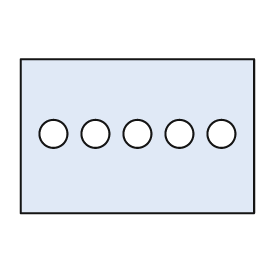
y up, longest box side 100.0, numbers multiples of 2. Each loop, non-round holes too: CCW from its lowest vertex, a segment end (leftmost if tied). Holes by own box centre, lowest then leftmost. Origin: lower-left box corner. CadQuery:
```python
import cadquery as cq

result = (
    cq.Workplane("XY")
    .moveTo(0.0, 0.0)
    .lineTo(100.0, 0.0)
    .lineTo(100.0, 66.0)
    .lineTo(0.0, 66.0)
    .close()
    .moveTo(14.0, 34.0)
    .circle(6.0)
    .moveTo(32.0, 34.0)
    .circle(6.0)
    .moveTo(50.0, 34.0)
    .circle(6.0)
    .moveTo(68.0, 34.0)
    .circle(6.0)
    .moveTo(86.0, 34.0)
    .circle(6.0)
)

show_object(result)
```